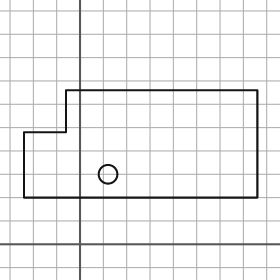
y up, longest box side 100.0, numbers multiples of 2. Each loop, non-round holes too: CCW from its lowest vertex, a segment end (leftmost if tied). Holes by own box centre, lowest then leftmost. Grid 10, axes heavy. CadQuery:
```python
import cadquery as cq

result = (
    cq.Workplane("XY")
    .moveTo(-24.0, 20.0)
    .lineTo(76.0, 20.0)
    .lineTo(76.0, 66.0)
    .lineTo(-6.0, 66.0)
    .lineTo(-6.0, 48.0)
    .lineTo(-24.0, 48.0)
    .close()
    .moveTo(12.0, 30.0)
    .circle(4.0)
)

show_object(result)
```